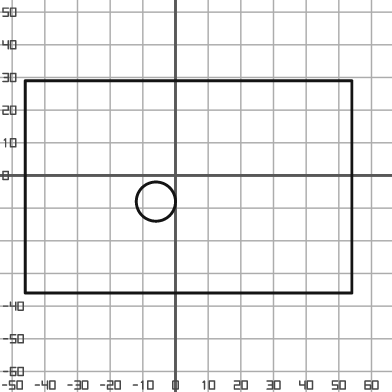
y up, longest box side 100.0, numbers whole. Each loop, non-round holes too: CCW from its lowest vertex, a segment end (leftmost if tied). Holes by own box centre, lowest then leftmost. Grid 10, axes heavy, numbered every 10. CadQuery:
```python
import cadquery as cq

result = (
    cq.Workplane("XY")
    .moveTo(-46.0, -36.0)
    .lineTo(54.0, -36.0)
    .lineTo(54.0, 29.0)
    .lineTo(-46.0, 29.0)
    .close()
    .moveTo(-6.0, -8.0)
    .circle(6.0)
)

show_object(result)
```